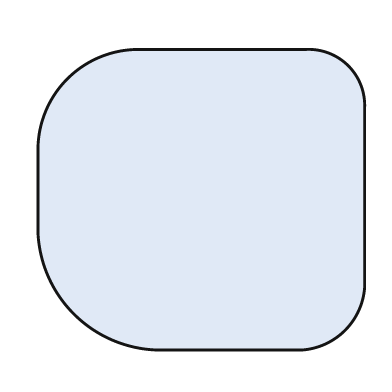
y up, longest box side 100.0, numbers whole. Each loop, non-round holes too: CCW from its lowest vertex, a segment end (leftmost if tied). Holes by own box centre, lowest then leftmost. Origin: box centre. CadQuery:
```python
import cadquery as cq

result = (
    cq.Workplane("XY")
    .moveTo(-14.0, -46.0)
    .lineTo(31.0, -46.0)
    .threePointArc((44.0, -40.0), (50.0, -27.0))
    .lineTo(50.0, 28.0)
    .threePointArc((45.0, 41.0), (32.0, 46.0))
    .lineTo(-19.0, 46.0)
    .threePointArc((-41.0, 37.0), (-50.0, 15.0))
    .lineTo(-50.0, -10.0)
    .threePointArc((-39.0, -35.0), (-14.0, -46.0))
    .close()
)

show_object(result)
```